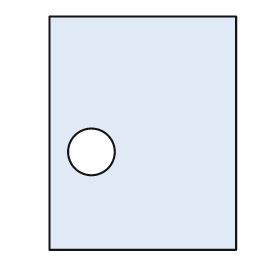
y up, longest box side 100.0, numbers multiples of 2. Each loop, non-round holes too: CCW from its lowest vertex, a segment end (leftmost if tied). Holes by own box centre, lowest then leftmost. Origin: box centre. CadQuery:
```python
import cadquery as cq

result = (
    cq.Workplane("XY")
    .moveTo(-40.0, -50.0)
    .lineTo(40.0, -50.0)
    .lineTo(40.0, 50.0)
    .lineTo(-40.0, 50.0)
    .close()
    .moveTo(-22.0, -8.0)
    .circle(10.0)
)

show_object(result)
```